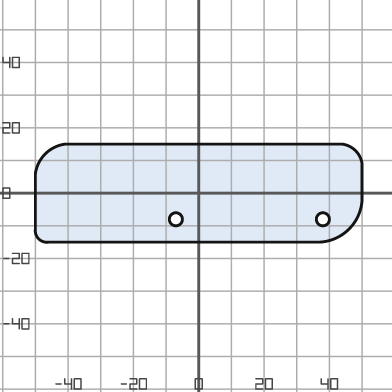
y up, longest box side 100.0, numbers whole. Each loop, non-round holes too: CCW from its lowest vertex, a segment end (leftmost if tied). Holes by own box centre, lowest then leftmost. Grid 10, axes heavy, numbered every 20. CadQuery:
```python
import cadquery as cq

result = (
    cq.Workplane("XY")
    .moveTo(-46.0, -15.0)
    .lineTo(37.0, -15.0)
    .threePointArc((46.0, -11.0), (50.0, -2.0))
    .lineTo(50.0, 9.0)
    .threePointArc((48.0, 13.0), (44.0, 15.0))
    .lineTo(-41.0, 15.0)
    .threePointArc((-47.0, 12.0), (-50.0, 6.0))
    .lineTo(-50.0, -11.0)
    .threePointArc((-49.0, -14.0), (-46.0, -15.0))
    .close()
    .moveTo(-7.0, -8.0)
    .circle(2.0)
    .moveTo(38.0, -8.0)
    .circle(2.0)
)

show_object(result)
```